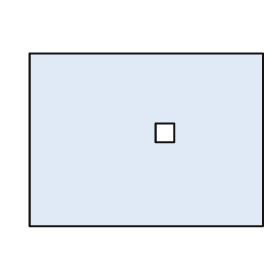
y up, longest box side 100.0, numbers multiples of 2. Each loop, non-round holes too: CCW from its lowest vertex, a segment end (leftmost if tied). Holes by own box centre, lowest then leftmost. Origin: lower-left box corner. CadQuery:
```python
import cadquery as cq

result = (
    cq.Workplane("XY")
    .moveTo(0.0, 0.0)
    .lineTo(100.0, 0.0)
    .lineTo(100.0, 74.0)
    .lineTo(0.0, 74.0)
    .close()
    .moveTo(54.0, 36.0)
    .lineTo(62.0, 36.0)
    .lineTo(62.0, 44.0)
    .lineTo(54.0, 44.0)
    .close()
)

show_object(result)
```